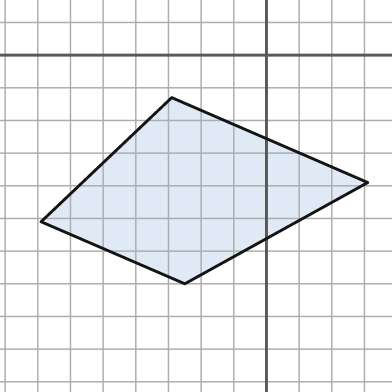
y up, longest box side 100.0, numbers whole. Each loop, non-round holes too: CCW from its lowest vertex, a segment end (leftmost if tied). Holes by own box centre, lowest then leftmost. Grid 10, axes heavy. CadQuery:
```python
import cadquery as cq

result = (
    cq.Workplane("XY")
    .moveTo(-25.0, -70.0)
    .lineTo(31.0, -39.0)
    .lineTo(-29.0, -13.0)
    .lineTo(-69.0, -51.0)
    .close()
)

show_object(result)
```